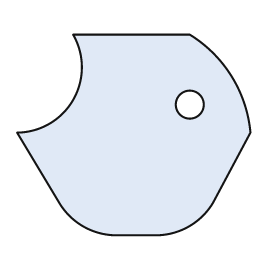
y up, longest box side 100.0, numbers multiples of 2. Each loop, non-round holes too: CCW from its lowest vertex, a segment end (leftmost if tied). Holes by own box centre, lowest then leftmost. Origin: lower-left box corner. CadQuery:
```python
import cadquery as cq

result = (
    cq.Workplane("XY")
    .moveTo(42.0, 0.0)
    .lineTo(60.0, 0.0)
    .threePointArc((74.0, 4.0), (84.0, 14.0))
    .lineTo(100.0, 44.0)
    .threePointArc((92.0, 68.0), (74.0, 86.0))
    .lineTo(24.0, 86.0)
    .threePointArc((24.0, 58.0), (0.0, 44.0))
    .lineTo(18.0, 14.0)
    .threePointArc((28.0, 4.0), (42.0, 0.0))
    .close()
    .moveTo(74.0, 56.0)
    .circle(6.0)
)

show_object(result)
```